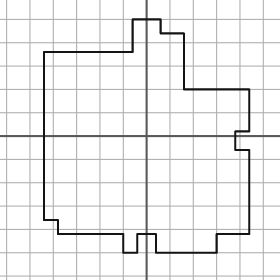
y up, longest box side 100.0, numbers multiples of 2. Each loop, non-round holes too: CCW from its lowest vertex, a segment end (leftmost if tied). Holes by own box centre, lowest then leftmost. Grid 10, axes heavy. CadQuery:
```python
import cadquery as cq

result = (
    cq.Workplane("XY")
    .moveTo(-10.0, -50.0)
    .lineTo(-4.0, -50.0)
    .lineTo(-4.0, -42.0)
    .lineTo(4.0, -42.0)
    .lineTo(4.0, -50.0)
    .lineTo(30.0, -50.0)
    .lineTo(30.0, -42.0)
    .lineTo(44.0, -42.0)
    .lineTo(44.0, -6.0)
    .lineTo(38.0, -6.0)
    .lineTo(38.0, 2.0)
    .lineTo(44.0, 2.0)
    .lineTo(44.0, 20.0)
    .lineTo(16.0, 20.0)
    .lineTo(16.0, 44.0)
    .lineTo(6.0, 44.0)
    .lineTo(6.0, 50.0)
    .lineTo(-6.0, 50.0)
    .lineTo(-6.0, 36.0)
    .lineTo(-44.0, 36.0)
    .lineTo(-44.0, -36.0)
    .lineTo(-38.0, -36.0)
    .lineTo(-38.0, -42.0)
    .lineTo(-10.0, -42.0)
    .close()
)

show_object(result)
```